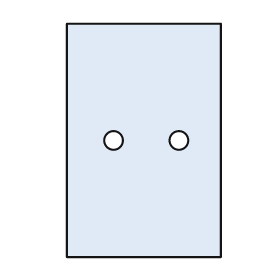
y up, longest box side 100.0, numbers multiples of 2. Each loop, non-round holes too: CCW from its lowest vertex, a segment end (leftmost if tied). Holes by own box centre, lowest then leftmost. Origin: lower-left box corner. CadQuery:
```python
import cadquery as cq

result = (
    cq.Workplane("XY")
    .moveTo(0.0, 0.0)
    .lineTo(66.0, 0.0)
    .lineTo(66.0, 100.0)
    .lineTo(0.0, 100.0)
    .close()
    .moveTo(20.0, 50.0)
    .circle(4.0)
    .moveTo(48.0, 50.0)
    .circle(4.0)
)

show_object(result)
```